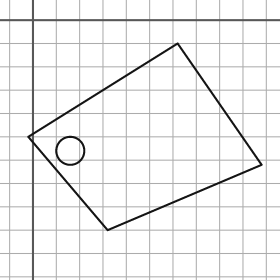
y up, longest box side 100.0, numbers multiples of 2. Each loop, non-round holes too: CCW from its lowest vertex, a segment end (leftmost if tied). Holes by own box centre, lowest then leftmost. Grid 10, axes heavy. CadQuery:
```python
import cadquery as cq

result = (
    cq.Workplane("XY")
    .moveTo(32.0, -90.0)
    .lineTo(98.0, -62.0)
    .lineTo(62.0, -10.0)
    .lineTo(-2.0, -50.0)
    .close()
    .moveTo(16.0, -56.0)
    .circle(6.0)
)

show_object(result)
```